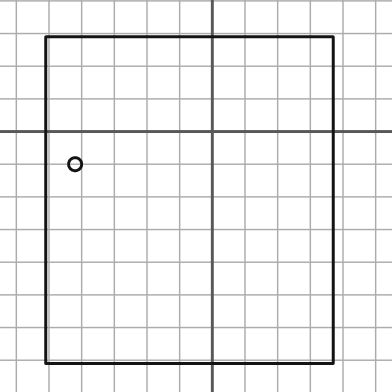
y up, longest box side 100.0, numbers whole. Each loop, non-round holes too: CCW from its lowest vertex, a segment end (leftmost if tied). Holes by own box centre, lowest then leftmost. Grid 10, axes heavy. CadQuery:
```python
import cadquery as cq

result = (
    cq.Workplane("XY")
    .moveTo(-51.0, -71.0)
    .lineTo(37.0, -71.0)
    .lineTo(37.0, 29.0)
    .lineTo(-51.0, 29.0)
    .close()
    .moveTo(-42.0, -10.0)
    .circle(2.0)
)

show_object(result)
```